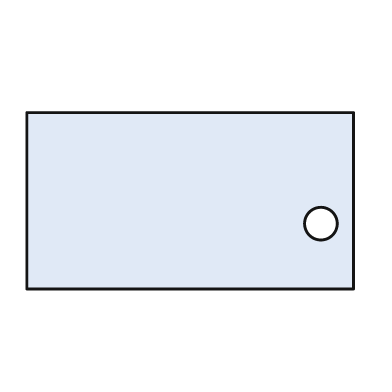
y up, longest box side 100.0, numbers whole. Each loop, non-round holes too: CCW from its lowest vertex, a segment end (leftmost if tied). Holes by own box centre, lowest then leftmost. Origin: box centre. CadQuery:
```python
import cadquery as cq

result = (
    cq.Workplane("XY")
    .moveTo(-50.0, -27.0)
    .lineTo(50.0, -27.0)
    .lineTo(50.0, 27.0)
    .lineTo(-50.0, 27.0)
    .close()
    .moveTo(40.0, -7.0)
    .circle(5.0)
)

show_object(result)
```